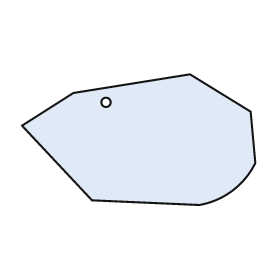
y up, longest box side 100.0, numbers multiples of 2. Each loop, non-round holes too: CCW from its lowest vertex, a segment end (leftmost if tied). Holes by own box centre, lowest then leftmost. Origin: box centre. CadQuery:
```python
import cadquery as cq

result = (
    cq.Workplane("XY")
    .moveTo(26.0, -28.0)
    .threePointArc((40.0, -22.0), (50.0, -10.0))
    .lineTo(48.0, 12.0)
    .lineTo(22.0, 28.0)
    .lineTo(-28.0, 20.0)
    .lineTo(-50.0, 6.0)
    .lineTo(-20.0, -26.0)
    .close()
    .moveTo(-14.0, 16.0)
    .circle(2.0)
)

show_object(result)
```